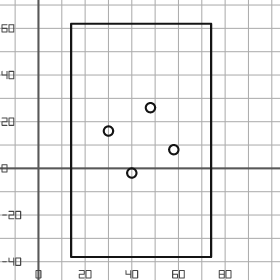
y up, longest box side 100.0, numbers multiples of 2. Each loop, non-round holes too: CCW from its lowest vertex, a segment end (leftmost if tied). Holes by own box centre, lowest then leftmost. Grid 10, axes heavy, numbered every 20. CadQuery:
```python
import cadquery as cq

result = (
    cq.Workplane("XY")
    .moveTo(14.0, -38.0)
    .lineTo(74.0, -38.0)
    .lineTo(74.0, 62.0)
    .lineTo(14.0, 62.0)
    .close()
    .moveTo(40.0, -2.0)
    .circle(2.0)
    .moveTo(58.0, 8.0)
    .circle(2.0)
    .moveTo(30.0, 16.0)
    .circle(2.0)
    .moveTo(48.0, 26.0)
    .circle(2.0)
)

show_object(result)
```